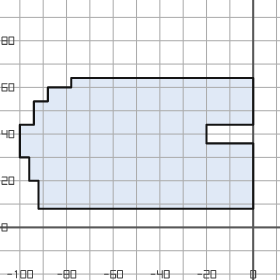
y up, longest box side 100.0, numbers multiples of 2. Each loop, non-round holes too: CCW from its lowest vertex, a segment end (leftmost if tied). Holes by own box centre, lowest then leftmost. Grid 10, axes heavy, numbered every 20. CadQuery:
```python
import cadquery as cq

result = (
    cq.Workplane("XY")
    .moveTo(-92.0, 8.0)
    .lineTo(0.0, 8.0)
    .lineTo(0.0, 36.0)
    .lineTo(-20.0, 36.0)
    .lineTo(-20.0, 44.0)
    .lineTo(0.0, 44.0)
    .lineTo(0.0, 64.0)
    .lineTo(-78.0, 64.0)
    .lineTo(-78.0, 60.0)
    .lineTo(-88.0, 60.0)
    .lineTo(-88.0, 54.0)
    .lineTo(-94.0, 54.0)
    .lineTo(-94.0, 44.0)
    .lineTo(-100.0, 44.0)
    .lineTo(-100.0, 30.0)
    .lineTo(-96.0, 30.0)
    .lineTo(-96.0, 20.0)
    .lineTo(-92.0, 20.0)
    .close()
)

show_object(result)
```